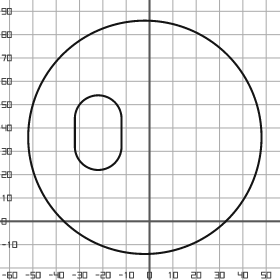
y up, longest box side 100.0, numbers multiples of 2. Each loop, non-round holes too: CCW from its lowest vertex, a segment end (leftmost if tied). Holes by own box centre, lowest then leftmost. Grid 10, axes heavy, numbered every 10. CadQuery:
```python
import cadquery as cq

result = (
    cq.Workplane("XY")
    .moveTo(-2.0, 36.0)
    .circle(50.0)
    .moveTo(-32.0, 32.0)
    .threePointArc((-22.0, 22.0), (-12.0, 32.0))
    .lineTo(-12.0, 44.0)
    .threePointArc((-22.0, 54.0), (-32.0, 44.0))
    .close()
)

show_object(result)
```